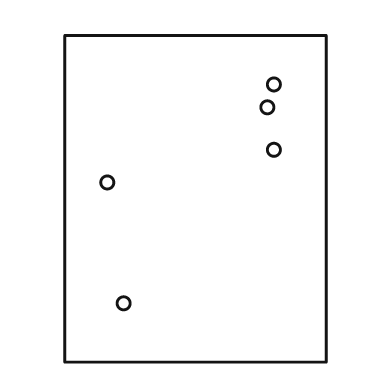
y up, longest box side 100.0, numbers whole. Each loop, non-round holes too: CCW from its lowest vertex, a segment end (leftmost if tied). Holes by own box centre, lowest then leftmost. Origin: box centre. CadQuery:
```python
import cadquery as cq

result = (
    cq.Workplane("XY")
    .moveTo(-40.0, -50.0)
    .lineTo(40.0, -50.0)
    .lineTo(40.0, 50.0)
    .lineTo(-40.0, 50.0)
    .close()
    .moveTo(-22.0, -32.0)
    .circle(2.0)
    .moveTo(-27.0, 5.0)
    .circle(2.0)
    .moveTo(24.0, 15.0)
    .circle(2.0)
    .moveTo(22.0, 28.0)
    .circle(2.0)
    .moveTo(24.0, 35.0)
    .circle(2.0)
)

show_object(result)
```